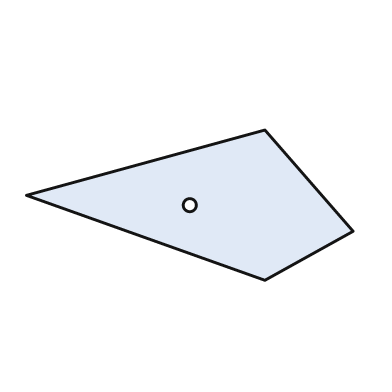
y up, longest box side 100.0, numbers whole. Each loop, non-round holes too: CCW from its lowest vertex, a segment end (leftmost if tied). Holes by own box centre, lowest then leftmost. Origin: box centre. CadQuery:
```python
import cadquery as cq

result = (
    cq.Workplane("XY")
    .moveTo(23.0, -23.0)
    .lineTo(50.0, -8.0)
    .lineTo(23.0, 23.0)
    .lineTo(-50.0, 3.0)
    .close()
    .moveTo(0.0, 0.0)
    .circle(2.0)
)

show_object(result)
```